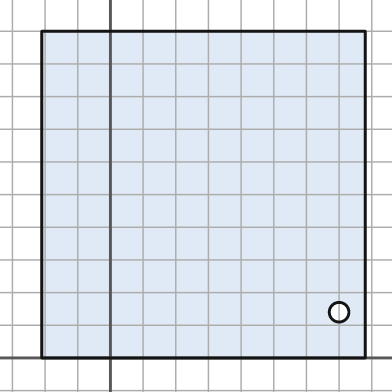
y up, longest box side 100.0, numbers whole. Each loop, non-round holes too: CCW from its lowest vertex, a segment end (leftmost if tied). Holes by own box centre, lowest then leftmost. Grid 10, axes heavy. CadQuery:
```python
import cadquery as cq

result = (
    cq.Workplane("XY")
    .moveTo(-21.0, 0.0)
    .lineTo(78.0, 0.0)
    .lineTo(78.0, 100.0)
    .lineTo(-21.0, 100.0)
    .close()
    .moveTo(70.0, 14.0)
    .circle(3.0)
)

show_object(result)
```